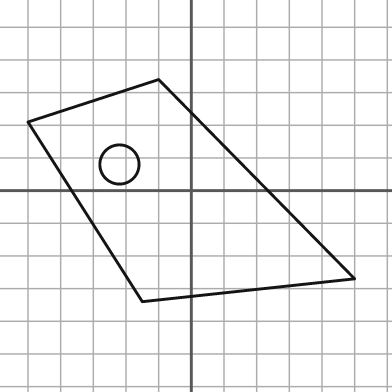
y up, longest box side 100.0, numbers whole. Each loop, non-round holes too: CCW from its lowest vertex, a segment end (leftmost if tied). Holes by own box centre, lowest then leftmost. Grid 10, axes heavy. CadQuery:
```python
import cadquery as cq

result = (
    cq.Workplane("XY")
    .moveTo(-15.0, -34.0)
    .lineTo(50.0, -27.0)
    .lineTo(-10.0, 34.0)
    .lineTo(-50.0, 21.0)
    .close()
    .moveTo(-22.0, 8.0)
    .circle(6.0)
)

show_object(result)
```